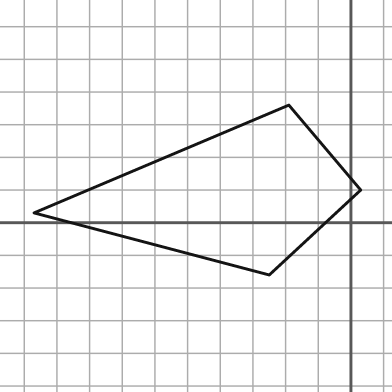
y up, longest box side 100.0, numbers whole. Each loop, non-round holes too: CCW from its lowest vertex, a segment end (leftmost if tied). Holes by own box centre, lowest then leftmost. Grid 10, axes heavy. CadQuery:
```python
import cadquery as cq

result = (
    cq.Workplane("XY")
    .moveTo(-25.0, -16.0)
    .lineTo(3.0, 10.0)
    .lineTo(-19.0, 36.0)
    .lineTo(-97.0, 3.0)
    .close()
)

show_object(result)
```